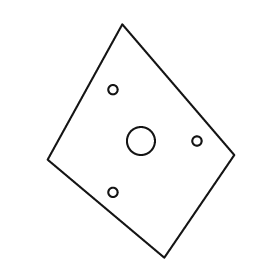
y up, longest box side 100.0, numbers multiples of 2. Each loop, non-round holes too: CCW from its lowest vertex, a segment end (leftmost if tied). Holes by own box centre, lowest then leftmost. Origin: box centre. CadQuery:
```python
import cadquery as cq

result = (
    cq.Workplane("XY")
    .moveTo(10.0, -50.0)
    .lineTo(40.0, -6.0)
    .lineTo(-8.0, 50.0)
    .lineTo(-40.0, -8.0)
    .close()
    .moveTo(-12.0, -22.0)
    .circle(2.0)
    .moveTo(0.0, 0.0)
    .circle(6.0)
    .moveTo(24.0, 0.0)
    .circle(2.0)
    .moveTo(-12.0, 22.0)
    .circle(2.0)
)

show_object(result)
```